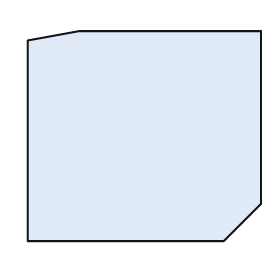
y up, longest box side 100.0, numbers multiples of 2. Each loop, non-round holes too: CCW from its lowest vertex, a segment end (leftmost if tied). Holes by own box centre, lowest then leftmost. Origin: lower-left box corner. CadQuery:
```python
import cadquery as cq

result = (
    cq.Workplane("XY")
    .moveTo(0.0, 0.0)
    .lineTo(84.0, 0.0)
    .lineTo(100.0, 16.0)
    .lineTo(100.0, 90.0)
    .lineTo(22.0, 90.0)
    .lineTo(0.0, 86.0)
    .close()
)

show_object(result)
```